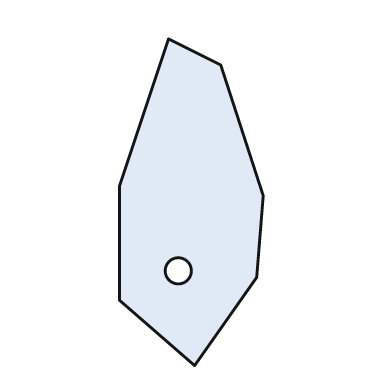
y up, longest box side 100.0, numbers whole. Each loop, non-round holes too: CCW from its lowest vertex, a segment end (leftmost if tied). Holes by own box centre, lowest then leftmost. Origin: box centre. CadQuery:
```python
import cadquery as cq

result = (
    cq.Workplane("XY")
    .moveTo(1.0, -50.0)
    .lineTo(20.0, -23.0)
    .lineTo(22.0, 2.0)
    .lineTo(9.0, 42.0)
    .lineTo(-7.0, 50.0)
    .lineTo(-22.0, 5.0)
    .lineTo(-22.0, -30.0)
    .close()
    .moveTo(-4.0, -21.0)
    .circle(4.0)
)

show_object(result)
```